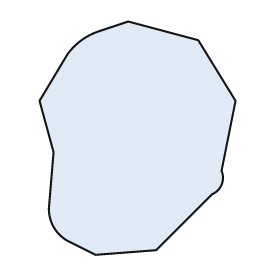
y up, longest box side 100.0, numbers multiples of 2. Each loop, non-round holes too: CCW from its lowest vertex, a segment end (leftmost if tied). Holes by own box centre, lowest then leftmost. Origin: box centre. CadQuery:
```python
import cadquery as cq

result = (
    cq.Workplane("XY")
    .moveTo(-18.0, -50.0)
    .lineTo(8.0, -48.0)
    .lineTo(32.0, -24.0)
    .threePointArc((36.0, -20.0), (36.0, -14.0))
    .lineTo(42.0, 16.0)
    .lineTo(26.0, 42.0)
    .lineTo(-4.0, 50.0)
    .lineTo(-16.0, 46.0)
    .threePointArc((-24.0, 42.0), (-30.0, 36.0))
    .lineTo(-42.0, 16.0)
    .lineTo(-36.0, -6.0)
    .lineTo(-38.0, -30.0)
    .threePointArc((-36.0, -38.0), (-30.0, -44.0))
    .close()
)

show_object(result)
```